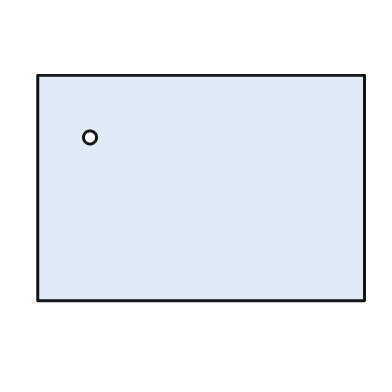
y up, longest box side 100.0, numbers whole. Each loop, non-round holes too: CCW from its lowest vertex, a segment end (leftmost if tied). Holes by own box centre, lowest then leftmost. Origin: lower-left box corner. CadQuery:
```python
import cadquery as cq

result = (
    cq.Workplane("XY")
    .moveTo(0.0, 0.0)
    .lineTo(100.0, 0.0)
    .lineTo(100.0, 69.0)
    .lineTo(0.0, 69.0)
    .close()
    .moveTo(16.0, 50.0)
    .circle(2.0)
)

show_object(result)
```